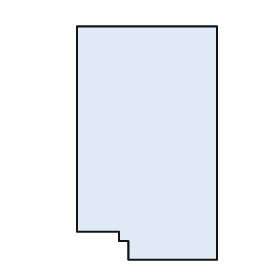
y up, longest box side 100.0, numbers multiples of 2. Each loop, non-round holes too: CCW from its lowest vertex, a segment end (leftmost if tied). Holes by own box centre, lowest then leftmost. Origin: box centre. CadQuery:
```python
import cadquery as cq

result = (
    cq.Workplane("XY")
    .moveTo(-8.0, -50.0)
    .lineTo(30.0, -50.0)
    .lineTo(30.0, 50.0)
    .lineTo(-30.0, 50.0)
    .lineTo(-30.0, -38.0)
    .lineTo(-12.0, -38.0)
    .lineTo(-12.0, -42.0)
    .lineTo(-8.0, -42.0)
    .close()
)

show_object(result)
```